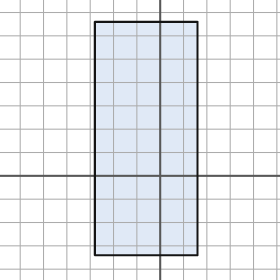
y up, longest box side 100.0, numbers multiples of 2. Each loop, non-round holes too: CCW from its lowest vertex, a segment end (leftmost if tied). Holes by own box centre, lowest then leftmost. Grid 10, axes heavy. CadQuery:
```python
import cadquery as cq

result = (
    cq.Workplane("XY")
    .moveTo(-28.0, -34.0)
    .lineTo(16.0, -34.0)
    .lineTo(16.0, 66.0)
    .lineTo(-28.0, 66.0)
    .close()
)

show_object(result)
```